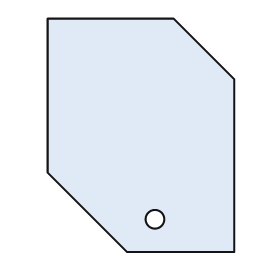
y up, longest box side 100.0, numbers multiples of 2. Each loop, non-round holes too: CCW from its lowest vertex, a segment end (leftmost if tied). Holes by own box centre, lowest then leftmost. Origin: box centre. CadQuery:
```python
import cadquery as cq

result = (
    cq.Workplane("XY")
    .moveTo(-6.0, -50.0)
    .lineTo(40.0, -50.0)
    .lineTo(40.0, 24.0)
    .lineTo(14.0, 50.0)
    .lineTo(-40.0, 50.0)
    .lineTo(-40.0, -16.0)
    .close()
    .moveTo(6.0, -36.0)
    .circle(4.0)
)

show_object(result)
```